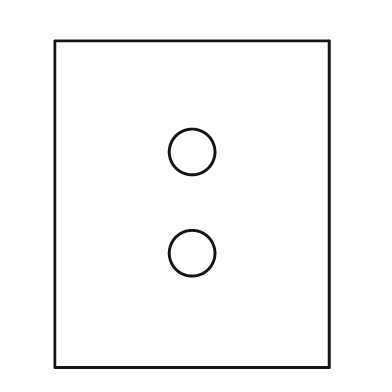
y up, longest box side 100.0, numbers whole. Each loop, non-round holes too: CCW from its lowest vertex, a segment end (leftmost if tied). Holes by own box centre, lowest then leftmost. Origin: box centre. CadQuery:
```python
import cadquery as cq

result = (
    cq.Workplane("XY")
    .moveTo(-42.0, -50.0)
    .lineTo(42.0, -50.0)
    .lineTo(42.0, 50.0)
    .lineTo(-42.0, 50.0)
    .close()
    .moveTo(0.0, -15.0)
    .circle(7.0)
    .moveTo(0.0, 16.0)
    .circle(7.0)
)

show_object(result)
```